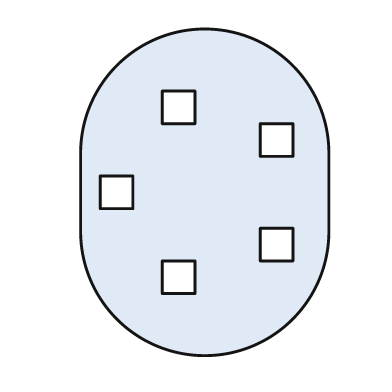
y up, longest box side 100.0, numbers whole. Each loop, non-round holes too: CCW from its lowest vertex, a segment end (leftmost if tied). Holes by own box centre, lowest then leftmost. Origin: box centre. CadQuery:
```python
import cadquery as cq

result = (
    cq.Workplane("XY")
    .moveTo(-38.0, -12.0)
    .threePointArc((0.0, -50.0), (38.0, -12.0))
    .lineTo(38.0, 12.0)
    .threePointArc((0.0, 50.0), (-38.0, 12.0))
    .close()
    .moveTo(-13.0, -31.0)
    .lineTo(-3.0, -31.0)
    .lineTo(-3.0, -21.0)
    .lineTo(-13.0, -21.0)
    .close()
    .moveTo(17.0, -21.0)
    .lineTo(27.0, -21.0)
    .lineTo(27.0, -11.0)
    .lineTo(17.0, -11.0)
    .close()
    .moveTo(-32.0, -5.0)
    .lineTo(-22.0, -5.0)
    .lineTo(-22.0, 5.0)
    .lineTo(-32.0, 5.0)
    .close()
    .moveTo(17.0, 11.0)
    .lineTo(27.0, 11.0)
    .lineTo(27.0, 21.0)
    .lineTo(17.0, 21.0)
    .close()
    .moveTo(-13.0, 21.0)
    .lineTo(-3.0, 21.0)
    .lineTo(-3.0, 31.0)
    .lineTo(-13.0, 31.0)
    .close()
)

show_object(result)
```